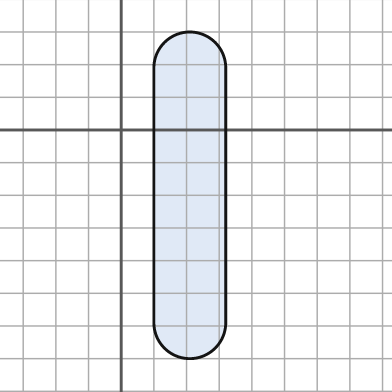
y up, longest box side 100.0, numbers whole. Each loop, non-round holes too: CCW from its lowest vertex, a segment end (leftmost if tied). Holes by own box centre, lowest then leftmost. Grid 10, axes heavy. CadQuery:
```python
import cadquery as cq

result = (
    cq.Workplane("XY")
    .moveTo(10.0, -59.0)
    .threePointArc((21.0, -70.0), (32.0, -59.0))
    .lineTo(32.0, 19.0)
    .threePointArc((21.0, 30.0), (10.0, 19.0))
    .close()
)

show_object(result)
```